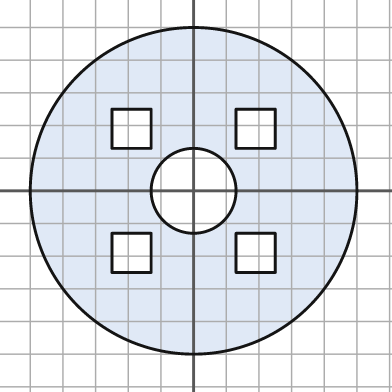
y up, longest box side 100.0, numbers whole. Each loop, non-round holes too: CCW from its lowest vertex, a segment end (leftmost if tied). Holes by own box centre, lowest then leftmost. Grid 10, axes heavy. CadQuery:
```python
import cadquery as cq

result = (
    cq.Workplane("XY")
    .moveTo(0.0, 0.0)
    .circle(50.0)
    .moveTo(-25.0, -25.0)
    .lineTo(-13.0, -25.0)
    .lineTo(-13.0, -13.0)
    .lineTo(-25.0, -13.0)
    .close()
    .moveTo(13.0, -25.0)
    .lineTo(25.0, -25.0)
    .lineTo(25.0, -13.0)
    .lineTo(13.0, -13.0)
    .close()
    .moveTo(0.0, 0.0)
    .circle(13.0)
    .moveTo(-25.0, 13.0)
    .lineTo(-13.0, 13.0)
    .lineTo(-13.0, 25.0)
    .lineTo(-25.0, 25.0)
    .close()
    .moveTo(13.0, 13.0)
    .lineTo(25.0, 13.0)
    .lineTo(25.0, 25.0)
    .lineTo(13.0, 25.0)
    .close()
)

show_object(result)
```